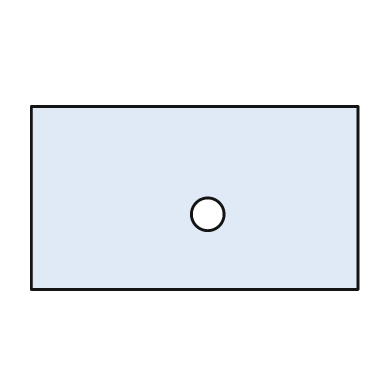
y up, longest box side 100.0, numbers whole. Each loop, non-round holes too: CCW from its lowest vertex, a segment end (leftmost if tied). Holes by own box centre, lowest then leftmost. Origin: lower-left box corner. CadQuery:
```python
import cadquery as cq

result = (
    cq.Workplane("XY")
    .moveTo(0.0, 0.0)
    .lineTo(100.0, 0.0)
    .lineTo(100.0, 56.0)
    .lineTo(0.0, 56.0)
    .close()
    .moveTo(54.0, 23.0)
    .circle(5.0)
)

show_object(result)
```